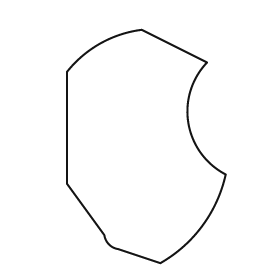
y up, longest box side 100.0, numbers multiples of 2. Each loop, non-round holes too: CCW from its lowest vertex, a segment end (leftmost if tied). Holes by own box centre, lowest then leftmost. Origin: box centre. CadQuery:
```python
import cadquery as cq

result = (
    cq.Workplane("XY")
    .moveTo(6.0, -50.0)
    .threePointArc((24.0, -34.0), (34.0, -12.0))
    .threePointArc((18.0, 10.0), (26.0, 36.0))
    .lineTo(-2.0, 50.0)
    .threePointArc((-20.0, 44.0), (-34.0, 32.0))
    .lineTo(-34.0, -16.0)
    .lineTo(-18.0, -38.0)
    .threePointArc((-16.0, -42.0), (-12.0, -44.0))
    .close()
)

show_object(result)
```